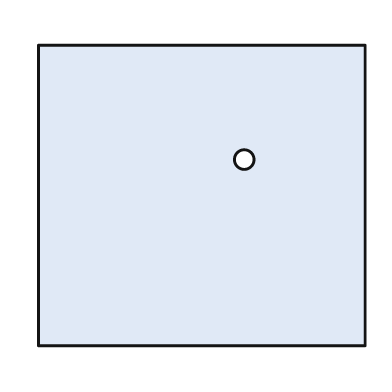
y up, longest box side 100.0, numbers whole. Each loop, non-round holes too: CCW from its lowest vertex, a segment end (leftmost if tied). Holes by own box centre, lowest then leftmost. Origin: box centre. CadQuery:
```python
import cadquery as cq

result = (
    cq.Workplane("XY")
    .moveTo(-50.0, -46.0)
    .lineTo(50.0, -46.0)
    .lineTo(50.0, 46.0)
    .lineTo(-50.0, 46.0)
    .close()
    .moveTo(13.0, 11.0)
    .circle(3.0)
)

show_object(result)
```